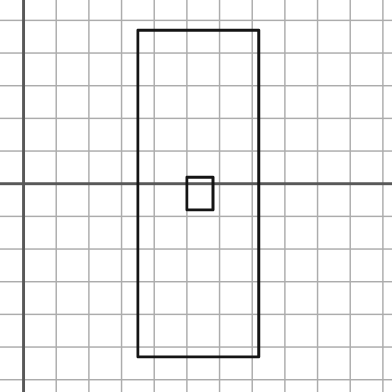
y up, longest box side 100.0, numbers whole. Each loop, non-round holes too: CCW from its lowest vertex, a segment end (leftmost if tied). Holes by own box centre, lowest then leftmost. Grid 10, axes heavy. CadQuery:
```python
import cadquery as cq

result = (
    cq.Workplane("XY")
    .moveTo(35.0, -53.0)
    .lineTo(72.0, -53.0)
    .lineTo(72.0, 47.0)
    .lineTo(35.0, 47.0)
    .close()
    .moveTo(50.0, -8.0)
    .lineTo(58.0, -8.0)
    .lineTo(58.0, 2.0)
    .lineTo(50.0, 2.0)
    .close()
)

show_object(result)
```